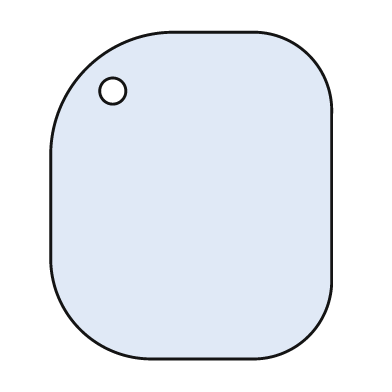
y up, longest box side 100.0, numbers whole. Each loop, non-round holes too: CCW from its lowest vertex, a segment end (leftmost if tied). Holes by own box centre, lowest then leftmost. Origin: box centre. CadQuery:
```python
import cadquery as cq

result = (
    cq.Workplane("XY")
    .moveTo(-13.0, -50.0)
    .lineTo(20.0, -50.0)
    .threePointArc((36.0, -43.0), (43.0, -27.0))
    .lineTo(43.0, 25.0)
    .threePointArc((36.0, 43.0), (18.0, 50.0))
    .lineTo(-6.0, 50.0)
    .threePointArc((-32.0, 39.0), (-43.0, 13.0))
    .lineTo(-43.0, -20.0)
    .threePointArc((-34.0, -41.0), (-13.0, -50.0))
    .close()
    .moveTo(-24.0, 32.0)
    .circle(4.0)
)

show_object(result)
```